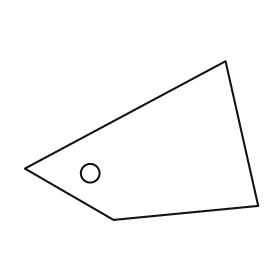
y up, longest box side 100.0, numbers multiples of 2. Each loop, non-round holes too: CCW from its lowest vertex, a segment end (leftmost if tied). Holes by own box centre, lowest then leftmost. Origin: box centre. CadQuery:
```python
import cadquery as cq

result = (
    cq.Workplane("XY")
    .moveTo(-12.0, -34.0)
    .lineTo(50.0, -28.0)
    .lineTo(36.0, 34.0)
    .lineTo(-50.0, -12.0)
    .close()
    .moveTo(-22.0, -14.0)
    .circle(4.0)
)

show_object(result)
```